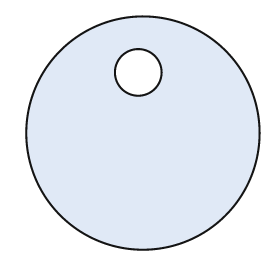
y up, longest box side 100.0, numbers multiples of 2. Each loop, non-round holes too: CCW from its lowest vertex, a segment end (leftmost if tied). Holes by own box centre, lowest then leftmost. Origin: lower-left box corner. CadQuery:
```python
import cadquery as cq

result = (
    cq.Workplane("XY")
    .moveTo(50.0, 50.0)
    .circle(50.0)
    .moveTo(48.0, 76.0)
    .circle(10.0)
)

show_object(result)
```